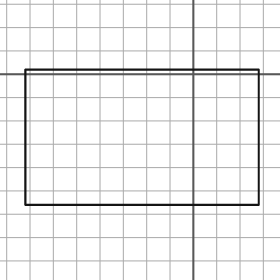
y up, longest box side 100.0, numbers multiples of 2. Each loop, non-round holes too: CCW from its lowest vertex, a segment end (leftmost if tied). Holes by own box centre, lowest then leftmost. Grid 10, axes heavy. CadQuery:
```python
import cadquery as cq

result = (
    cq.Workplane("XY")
    .moveTo(-72.0, -56.0)
    .lineTo(28.0, -56.0)
    .lineTo(28.0, 2.0)
    .lineTo(-72.0, 2.0)
    .close()
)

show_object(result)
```